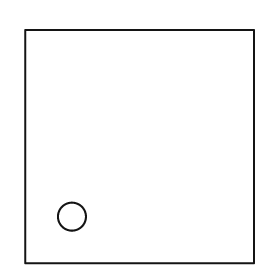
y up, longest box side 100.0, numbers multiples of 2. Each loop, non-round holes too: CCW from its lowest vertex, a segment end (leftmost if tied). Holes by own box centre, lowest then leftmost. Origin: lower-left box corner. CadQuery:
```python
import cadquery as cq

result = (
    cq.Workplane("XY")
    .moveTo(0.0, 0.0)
    .lineTo(98.0, 0.0)
    .lineTo(98.0, 100.0)
    .lineTo(0.0, 100.0)
    .close()
    .moveTo(20.0, 20.0)
    .circle(6.0)
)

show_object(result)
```